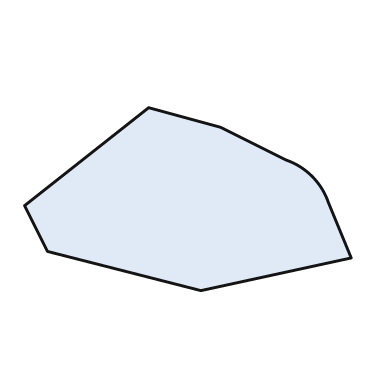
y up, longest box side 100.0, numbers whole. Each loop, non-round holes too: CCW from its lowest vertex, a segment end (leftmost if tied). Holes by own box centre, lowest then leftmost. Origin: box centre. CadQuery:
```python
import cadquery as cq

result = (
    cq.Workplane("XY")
    .moveTo(4.0, -28.0)
    .lineTo(50.0, -18.0)
    .lineTo(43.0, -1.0)
    .threePointArc((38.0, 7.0), (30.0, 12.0))
    .lineTo(10.0, 22.0)
    .lineTo(-12.0, 28.0)
    .lineTo(-50.0, -2.0)
    .lineTo(-43.0, -16.0)
    .close()
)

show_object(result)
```